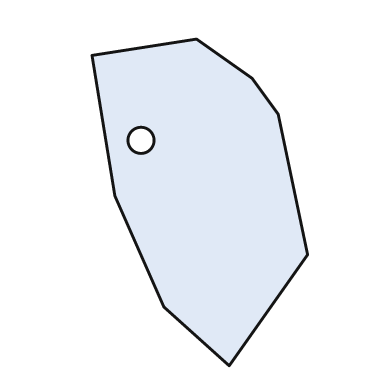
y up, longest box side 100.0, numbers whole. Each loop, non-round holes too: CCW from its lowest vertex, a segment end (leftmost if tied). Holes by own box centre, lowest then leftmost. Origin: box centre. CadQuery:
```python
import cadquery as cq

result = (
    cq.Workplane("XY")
    .moveTo(9.0, -50.0)
    .lineTo(33.0, -16.0)
    .lineTo(24.0, 27.0)
    .lineTo(16.0, 38.0)
    .lineTo(-1.0, 50.0)
    .lineTo(-33.0, 45.0)
    .lineTo(-26.0, 2.0)
    .lineTo(-11.0, -32.0)
    .close()
    .moveTo(-18.0, 19.0)
    .circle(4.0)
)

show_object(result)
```